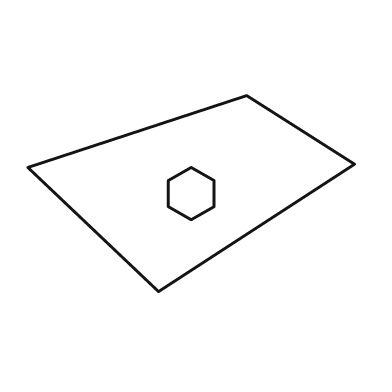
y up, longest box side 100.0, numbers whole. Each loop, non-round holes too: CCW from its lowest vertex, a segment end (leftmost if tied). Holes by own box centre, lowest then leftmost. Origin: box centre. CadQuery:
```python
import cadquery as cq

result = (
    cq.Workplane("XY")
    .moveTo(-10.0, -30.0)
    .lineTo(50.0, 9.0)
    .lineTo(17.0, 30.0)
    .lineTo(-50.0, 8.0)
    .close()
    .moveTo(0.0, -8.0)
    .lineTo(7.0, -4.0)
    .lineTo(7.0, 4.0)
    .lineTo(0.0, 8.0)
    .lineTo(-7.0, 4.0)
    .lineTo(-7.0, -4.0)
    .close()
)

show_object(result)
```